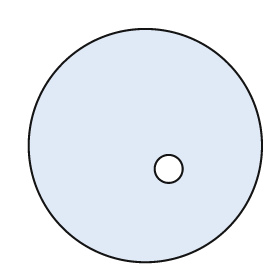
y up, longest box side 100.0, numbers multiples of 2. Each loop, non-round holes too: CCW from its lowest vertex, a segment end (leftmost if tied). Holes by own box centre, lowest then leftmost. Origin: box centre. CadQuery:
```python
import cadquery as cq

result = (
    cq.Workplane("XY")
    .moveTo(0.0, 0.0)
    .circle(50.0)
    .moveTo(10.0, -10.0)
    .circle(6.0)
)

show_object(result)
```